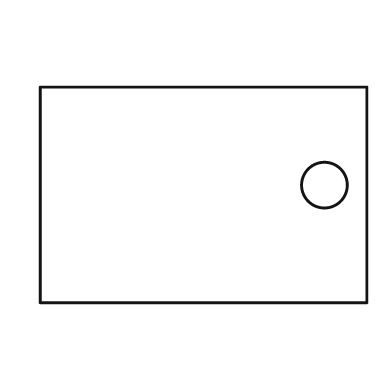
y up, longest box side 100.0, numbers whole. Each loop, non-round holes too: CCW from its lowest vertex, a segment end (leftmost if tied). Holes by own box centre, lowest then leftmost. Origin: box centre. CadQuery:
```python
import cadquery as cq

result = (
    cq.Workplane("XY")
    .moveTo(-50.0, -33.0)
    .lineTo(50.0, -33.0)
    .lineTo(50.0, 33.0)
    .lineTo(-50.0, 33.0)
    .close()
    .moveTo(37.0, 3.0)
    .circle(7.0)
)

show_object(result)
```